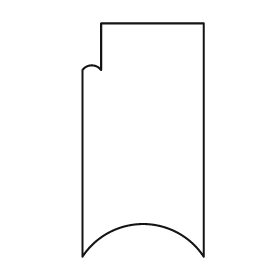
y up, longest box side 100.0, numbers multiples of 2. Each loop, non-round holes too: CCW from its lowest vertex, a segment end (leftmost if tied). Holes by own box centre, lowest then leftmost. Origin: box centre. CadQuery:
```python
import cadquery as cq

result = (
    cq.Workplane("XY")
    .moveTo(-26.0, -50.0)
    .threePointArc((0.0, -36.0), (26.0, -50.0))
    .lineTo(26.0, 50.0)
    .lineTo(-18.0, 50.0)
    .lineTo(-18.0, 30.0)
    .threePointArc((-22.0, 32.0), (-26.0, 30.0))
    .close()
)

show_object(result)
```